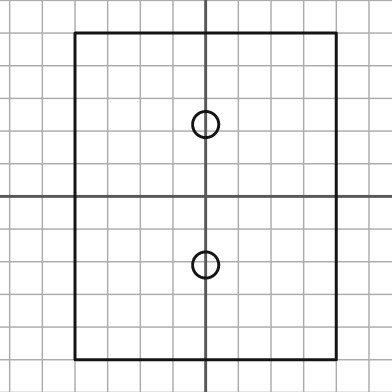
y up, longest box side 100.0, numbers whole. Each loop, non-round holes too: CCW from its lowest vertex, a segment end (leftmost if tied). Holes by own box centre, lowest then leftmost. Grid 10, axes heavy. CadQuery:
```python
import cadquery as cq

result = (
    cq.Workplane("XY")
    .moveTo(-40.0, -50.0)
    .lineTo(40.0, -50.0)
    .lineTo(40.0, 50.0)
    .lineTo(-40.0, 50.0)
    .close()
    .moveTo(0.0, -21.0)
    .circle(4.0)
    .moveTo(0.0, 22.0)
    .circle(4.0)
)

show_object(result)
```